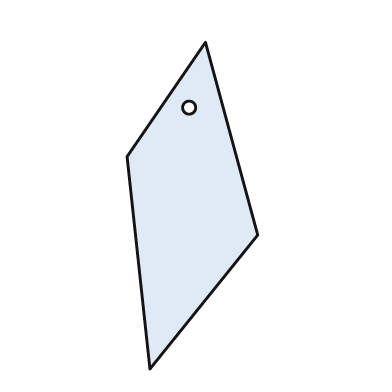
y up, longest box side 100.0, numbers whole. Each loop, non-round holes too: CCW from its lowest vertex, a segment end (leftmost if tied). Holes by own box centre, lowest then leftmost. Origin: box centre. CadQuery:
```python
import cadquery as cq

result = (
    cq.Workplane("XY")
    .moveTo(-13.0, -50.0)
    .lineTo(20.0, -9.0)
    .lineTo(4.0, 50.0)
    .lineTo(-20.0, 15.0)
    .close()
    .moveTo(-1.0, 30.0)
    .circle(2.0)
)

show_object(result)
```